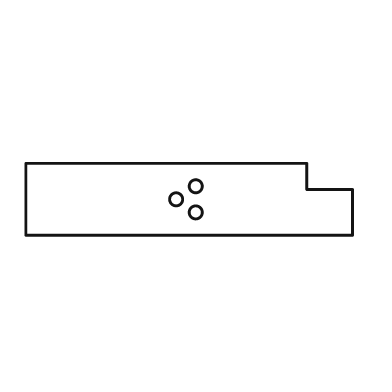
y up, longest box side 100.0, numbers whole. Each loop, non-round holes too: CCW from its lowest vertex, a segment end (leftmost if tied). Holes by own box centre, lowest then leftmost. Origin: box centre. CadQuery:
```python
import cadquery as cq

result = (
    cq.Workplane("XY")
    .moveTo(-50.0, -11.0)
    .lineTo(50.0, -11.0)
    .lineTo(50.0, 3.0)
    .lineTo(36.0, 3.0)
    .lineTo(36.0, 11.0)
    .lineTo(-50.0, 11.0)
    .close()
    .moveTo(2.0, -4.0)
    .circle(2.0)
    .moveTo(-4.0, 0.0)
    .circle(2.0)
    .moveTo(2.0, 4.0)
    .circle(2.0)
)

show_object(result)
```